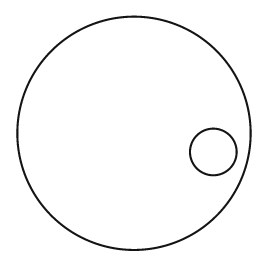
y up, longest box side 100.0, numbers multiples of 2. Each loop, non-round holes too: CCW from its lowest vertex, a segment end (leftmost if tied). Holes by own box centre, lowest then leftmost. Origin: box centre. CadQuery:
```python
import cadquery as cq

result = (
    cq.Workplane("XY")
    .moveTo(0.0, 0.0)
    .circle(50.0)
    .moveTo(34.0, -8.0)
    .circle(10.0)
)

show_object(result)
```